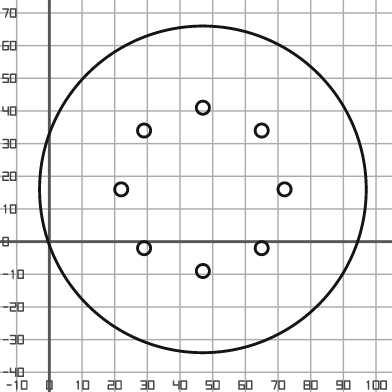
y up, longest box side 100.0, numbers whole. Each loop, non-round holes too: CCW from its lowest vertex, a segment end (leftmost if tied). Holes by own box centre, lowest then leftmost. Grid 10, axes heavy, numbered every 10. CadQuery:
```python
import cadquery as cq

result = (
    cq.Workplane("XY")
    .moveTo(47.0, 16.0)
    .circle(50.0)
    .moveTo(47.0, -9.0)
    .circle(2.0)
    .moveTo(29.0, -2.0)
    .circle(2.0)
    .moveTo(65.0, -2.0)
    .circle(2.0)
    .moveTo(22.0, 16.0)
    .circle(2.0)
    .moveTo(72.0, 16.0)
    .circle(2.0)
    .moveTo(29.0, 34.0)
    .circle(2.0)
    .moveTo(65.0, 34.0)
    .circle(2.0)
    .moveTo(47.0, 41.0)
    .circle(2.0)
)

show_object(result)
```